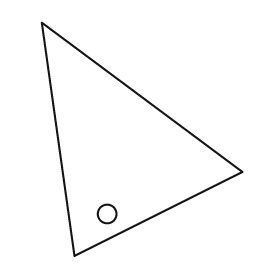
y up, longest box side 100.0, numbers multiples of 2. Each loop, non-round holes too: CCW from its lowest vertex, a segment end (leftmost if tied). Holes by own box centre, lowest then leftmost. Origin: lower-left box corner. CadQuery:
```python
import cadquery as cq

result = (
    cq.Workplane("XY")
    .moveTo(14.0, 0.0)
    .lineTo(86.0, 36.0)
    .lineTo(0.0, 100.0)
    .close()
    .moveTo(28.0, 18.0)
    .circle(4.0)
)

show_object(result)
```